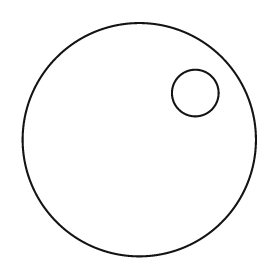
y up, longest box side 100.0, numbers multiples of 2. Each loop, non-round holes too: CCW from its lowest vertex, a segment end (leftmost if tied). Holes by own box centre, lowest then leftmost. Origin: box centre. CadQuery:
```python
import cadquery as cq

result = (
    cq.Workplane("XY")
    .moveTo(0.0, 0.0)
    .circle(50.0)
    .moveTo(24.0, 20.0)
    .circle(10.0)
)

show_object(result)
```